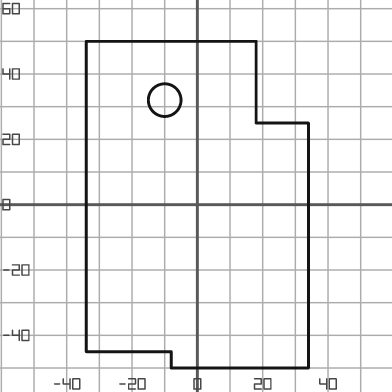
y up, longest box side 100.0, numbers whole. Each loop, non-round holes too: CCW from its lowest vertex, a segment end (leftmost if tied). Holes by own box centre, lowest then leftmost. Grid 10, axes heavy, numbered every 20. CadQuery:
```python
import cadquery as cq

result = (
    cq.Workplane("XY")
    .moveTo(-8.0, -50.0)
    .lineTo(34.0, -50.0)
    .lineTo(34.0, 25.0)
    .lineTo(18.0, 25.0)
    .lineTo(18.0, 50.0)
    .lineTo(-34.0, 50.0)
    .lineTo(-34.0, -45.0)
    .lineTo(-8.0, -45.0)
    .close()
    .moveTo(-10.0, 32.0)
    .circle(5.0)
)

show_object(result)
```